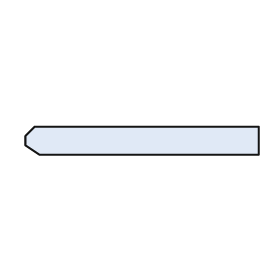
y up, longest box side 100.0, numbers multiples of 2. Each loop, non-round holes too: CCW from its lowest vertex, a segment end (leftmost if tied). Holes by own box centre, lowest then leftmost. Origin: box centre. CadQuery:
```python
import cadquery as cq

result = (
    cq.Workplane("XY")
    .moveTo(-44.0, -6.0)
    .lineTo(50.0, -6.0)
    .lineTo(50.0, 6.0)
    .lineTo(-46.0, 6.0)
    .lineTo(-50.0, 2.0)
    .lineTo(-50.0, -2.0)
    .close()
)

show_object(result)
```